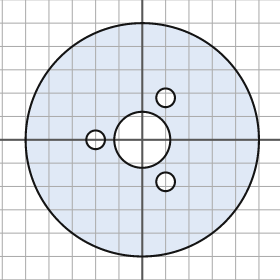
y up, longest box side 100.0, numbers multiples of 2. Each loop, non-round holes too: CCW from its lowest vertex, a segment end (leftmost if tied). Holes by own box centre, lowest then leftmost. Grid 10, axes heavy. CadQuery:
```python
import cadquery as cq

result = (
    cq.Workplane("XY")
    .moveTo(0.0, 0.0)
    .circle(50.0)
    .moveTo(10.0, -18.0)
    .circle(4.0)
    .moveTo(-20.0, 0.0)
    .circle(4.0)
    .moveTo(0.0, 0.0)
    .circle(12.0)
    .moveTo(10.0, 18.0)
    .circle(4.0)
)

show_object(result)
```